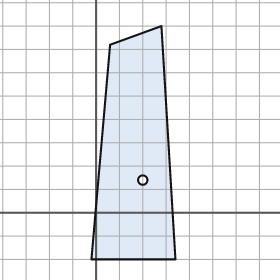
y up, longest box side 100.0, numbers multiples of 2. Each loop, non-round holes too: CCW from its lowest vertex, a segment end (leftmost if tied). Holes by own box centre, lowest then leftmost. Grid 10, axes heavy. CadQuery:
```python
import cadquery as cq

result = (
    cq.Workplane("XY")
    .moveTo(-2.0, -20.0)
    .lineTo(34.0, -20.0)
    .lineTo(28.0, 80.0)
    .lineTo(6.0, 72.0)
    .close()
    .moveTo(20.0, 14.0)
    .circle(2.0)
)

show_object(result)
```